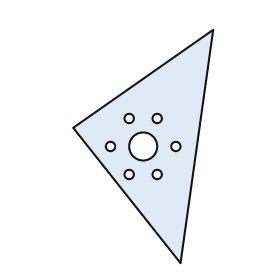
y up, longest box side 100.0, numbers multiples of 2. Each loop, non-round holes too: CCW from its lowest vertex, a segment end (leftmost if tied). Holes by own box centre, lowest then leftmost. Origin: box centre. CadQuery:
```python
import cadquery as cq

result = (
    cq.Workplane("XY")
    .moveTo(16.0, -50.0)
    .lineTo(30.0, 50.0)
    .lineTo(-30.0, 8.0)
    .close()
    .moveTo(-6.0, -12.0)
    .circle(2.0)
    .moveTo(6.0, -12.0)
    .circle(2.0)
    .moveTo(-14.0, 0.0)
    .circle(2.0)
    .moveTo(0.0, 0.0)
    .circle(6.0)
    .moveTo(14.0, 0.0)
    .circle(2.0)
    .moveTo(-6.0, 12.0)
    .circle(2.0)
    .moveTo(6.0, 12.0)
    .circle(2.0)
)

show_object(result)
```